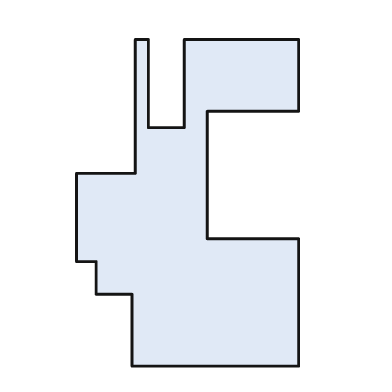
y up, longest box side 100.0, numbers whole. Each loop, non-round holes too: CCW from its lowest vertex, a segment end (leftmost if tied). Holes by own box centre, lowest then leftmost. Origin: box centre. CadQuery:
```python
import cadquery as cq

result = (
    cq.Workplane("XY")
    .moveTo(-17.0, -50.0)
    .lineTo(34.0, -50.0)
    .lineTo(34.0, -11.0)
    .lineTo(6.0, -11.0)
    .lineTo(6.0, 28.0)
    .lineTo(34.0, 28.0)
    .lineTo(34.0, 50.0)
    .lineTo(-1.0, 50.0)
    .lineTo(-1.0, 23.0)
    .lineTo(-12.0, 23.0)
    .lineTo(-12.0, 50.0)
    .lineTo(-16.0, 50.0)
    .lineTo(-16.0, 9.0)
    .lineTo(-34.0, 9.0)
    .lineTo(-34.0, -18.0)
    .lineTo(-28.0, -18.0)
    .lineTo(-28.0, -28.0)
    .lineTo(-17.0, -28.0)
    .close()
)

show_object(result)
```